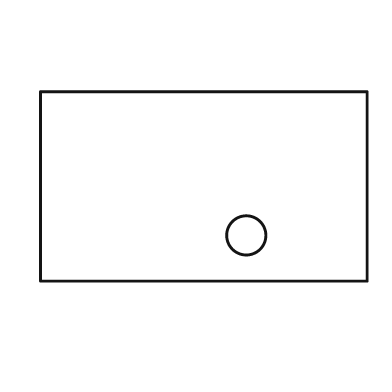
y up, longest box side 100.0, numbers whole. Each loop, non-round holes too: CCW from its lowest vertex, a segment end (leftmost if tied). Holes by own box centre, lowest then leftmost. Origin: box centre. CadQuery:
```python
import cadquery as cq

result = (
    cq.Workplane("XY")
    .moveTo(-50.0, -29.0)
    .lineTo(50.0, -29.0)
    .lineTo(50.0, 29.0)
    .lineTo(-50.0, 29.0)
    .close()
    .moveTo(13.0, -15.0)
    .circle(6.0)
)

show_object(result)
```